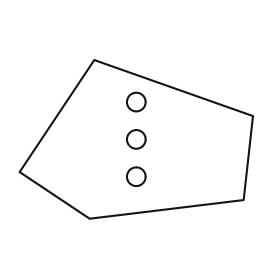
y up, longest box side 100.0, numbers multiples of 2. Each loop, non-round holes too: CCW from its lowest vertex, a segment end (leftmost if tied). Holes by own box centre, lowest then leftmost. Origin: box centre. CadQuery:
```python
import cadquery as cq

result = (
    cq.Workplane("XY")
    .moveTo(-20.0, -34.0)
    .lineTo(46.0, -26.0)
    .lineTo(50.0, 10.0)
    .lineTo(-18.0, 34.0)
    .lineTo(-50.0, -14.0)
    .close()
    .moveTo(0.0, -16.0)
    .circle(4.0)
    .moveTo(0.0, 0.0)
    .circle(4.0)
    .moveTo(0.0, 16.0)
    .circle(4.0)
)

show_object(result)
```